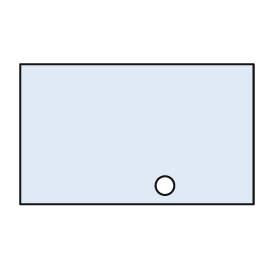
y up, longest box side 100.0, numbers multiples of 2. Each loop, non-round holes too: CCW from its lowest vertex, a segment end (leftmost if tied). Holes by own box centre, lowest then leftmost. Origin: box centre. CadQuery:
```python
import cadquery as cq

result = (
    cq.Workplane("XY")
    .moveTo(-50.0, -30.0)
    .lineTo(50.0, -30.0)
    .lineTo(50.0, 30.0)
    .lineTo(-50.0, 30.0)
    .close()
    .moveTo(12.0, -22.0)
    .circle(4.0)
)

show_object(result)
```